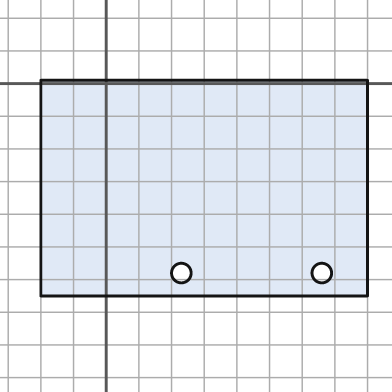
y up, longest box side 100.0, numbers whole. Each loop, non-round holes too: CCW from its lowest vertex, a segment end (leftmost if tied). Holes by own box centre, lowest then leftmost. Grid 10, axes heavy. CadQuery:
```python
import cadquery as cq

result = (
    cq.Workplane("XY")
    .moveTo(-20.0, -65.0)
    .lineTo(80.0, -65.0)
    .lineTo(80.0, 1.0)
    .lineTo(-20.0, 1.0)
    .close()
    .moveTo(23.0, -58.0)
    .circle(3.0)
    .moveTo(66.0, -58.0)
    .circle(3.0)
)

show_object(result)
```